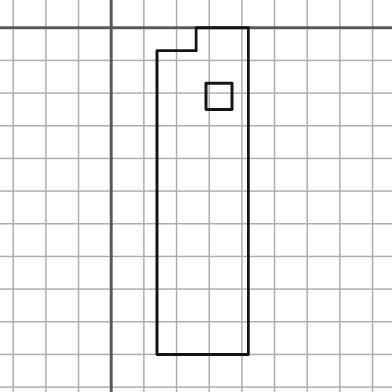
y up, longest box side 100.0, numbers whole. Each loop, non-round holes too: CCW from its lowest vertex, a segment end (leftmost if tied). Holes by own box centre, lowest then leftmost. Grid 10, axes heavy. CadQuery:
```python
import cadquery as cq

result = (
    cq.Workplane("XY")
    .moveTo(14.0, -100.0)
    .lineTo(42.0, -100.0)
    .lineTo(42.0, 0.0)
    .lineTo(26.0, 0.0)
    .lineTo(26.0, -7.0)
    .lineTo(14.0, -7.0)
    .close()
    .moveTo(29.0, -25.0)
    .lineTo(37.0, -25.0)
    .lineTo(37.0, -17.0)
    .lineTo(29.0, -17.0)
    .close()
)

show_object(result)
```